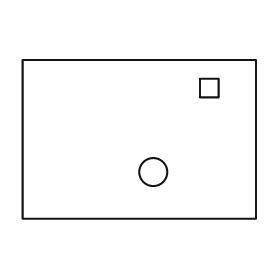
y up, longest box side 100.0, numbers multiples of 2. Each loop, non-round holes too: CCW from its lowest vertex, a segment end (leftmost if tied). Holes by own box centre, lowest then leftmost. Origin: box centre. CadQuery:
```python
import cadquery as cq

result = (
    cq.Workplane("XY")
    .moveTo(-50.0, -34.0)
    .lineTo(50.0, -34.0)
    .lineTo(50.0, 34.0)
    .lineTo(-50.0, 34.0)
    .close()
    .moveTo(6.0, -14.0)
    .circle(6.0)
    .moveTo(26.0, 18.0)
    .lineTo(34.0, 18.0)
    .lineTo(34.0, 26.0)
    .lineTo(26.0, 26.0)
    .close()
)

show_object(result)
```